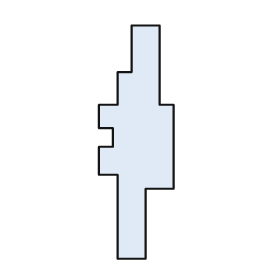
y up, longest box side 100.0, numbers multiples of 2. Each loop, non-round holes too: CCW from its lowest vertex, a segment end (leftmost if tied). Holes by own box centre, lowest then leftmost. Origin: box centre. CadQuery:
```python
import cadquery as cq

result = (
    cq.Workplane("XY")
    .moveTo(-8.0, -50.0)
    .lineTo(4.0, -50.0)
    .lineTo(4.0, -20.0)
    .lineTo(16.0, -20.0)
    .lineTo(16.0, 16.0)
    .lineTo(10.0, 16.0)
    .lineTo(10.0, 50.0)
    .lineTo(-2.0, 50.0)
    .lineTo(-2.0, 30.0)
    .lineTo(-8.0, 30.0)
    .lineTo(-8.0, 16.0)
    .lineTo(-16.0, 16.0)
    .lineTo(-16.0, 6.0)
    .lineTo(-10.0, 6.0)
    .lineTo(-10.0, -2.0)
    .lineTo(-16.0, -2.0)
    .lineTo(-16.0, -14.0)
    .lineTo(-8.0, -14.0)
    .close()
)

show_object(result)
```